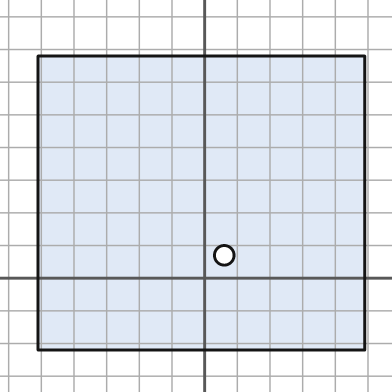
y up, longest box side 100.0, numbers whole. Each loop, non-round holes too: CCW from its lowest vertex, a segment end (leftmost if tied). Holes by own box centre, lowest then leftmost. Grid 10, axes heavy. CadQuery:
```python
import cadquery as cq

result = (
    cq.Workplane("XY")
    .moveTo(-51.0, -22.0)
    .lineTo(49.0, -22.0)
    .lineTo(49.0, 68.0)
    .lineTo(-51.0, 68.0)
    .close()
    .moveTo(6.0, 7.0)
    .circle(3.0)
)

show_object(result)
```